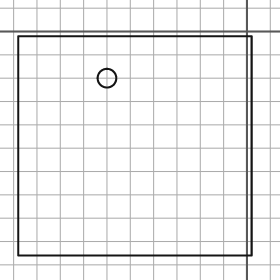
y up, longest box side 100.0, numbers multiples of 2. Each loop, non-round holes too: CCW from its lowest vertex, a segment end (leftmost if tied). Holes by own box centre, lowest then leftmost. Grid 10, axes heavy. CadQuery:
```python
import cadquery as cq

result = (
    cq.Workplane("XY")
    .moveTo(-98.0, -96.0)
    .lineTo(2.0, -96.0)
    .lineTo(2.0, -2.0)
    .lineTo(-98.0, -2.0)
    .close()
    .moveTo(-60.0, -20.0)
    .circle(4.0)
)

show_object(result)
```